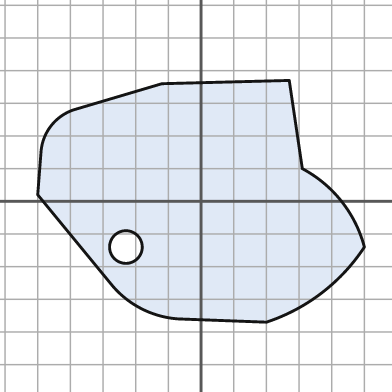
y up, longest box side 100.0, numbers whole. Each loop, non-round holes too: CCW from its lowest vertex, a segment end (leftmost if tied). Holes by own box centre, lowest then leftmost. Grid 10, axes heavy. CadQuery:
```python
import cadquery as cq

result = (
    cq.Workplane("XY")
    .moveTo(20.0, -37.0)
    .threePointArc((37.0, -28.0), (50.0, -14.0))
    .threePointArc((43.0, 0.0), (31.0, 10.0))
    .lineTo(27.0, 37.0)
    .lineTo(-12.0, 36.0)
    .lineTo(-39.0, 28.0)
    .threePointArc((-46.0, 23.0), (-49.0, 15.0))
    .lineTo(-50.0, 2.0)
    .lineTo(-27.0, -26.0)
    .threePointArc((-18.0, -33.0), (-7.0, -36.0))
    .close()
    .moveTo(-23.0, -14.0)
    .circle(5.0)
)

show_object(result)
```